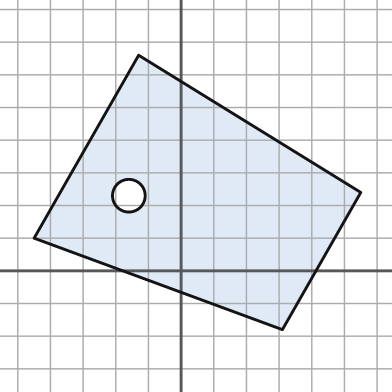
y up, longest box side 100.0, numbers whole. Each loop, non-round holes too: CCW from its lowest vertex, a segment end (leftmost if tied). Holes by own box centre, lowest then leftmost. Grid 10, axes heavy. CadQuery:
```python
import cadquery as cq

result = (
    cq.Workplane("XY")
    .moveTo(31.0, -18.0)
    .lineTo(55.0, 24.0)
    .lineTo(-13.0, 66.0)
    .lineTo(-45.0, 10.0)
    .close()
    .moveTo(-16.0, 23.0)
    .circle(5.0)
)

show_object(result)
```